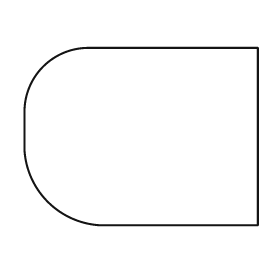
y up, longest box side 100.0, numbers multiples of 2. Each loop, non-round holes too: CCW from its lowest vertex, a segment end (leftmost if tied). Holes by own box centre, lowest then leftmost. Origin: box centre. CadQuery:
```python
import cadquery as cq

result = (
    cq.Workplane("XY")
    .moveTo(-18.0, -38.0)
    .lineTo(50.0, -38.0)
    .lineTo(50.0, 38.0)
    .lineTo(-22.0, 38.0)
    .threePointArc((-42.0, 30.0), (-50.0, 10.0))
    .lineTo(-50.0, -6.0)
    .threePointArc((-40.0, -28.0), (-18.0, -38.0))
    .close()
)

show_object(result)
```